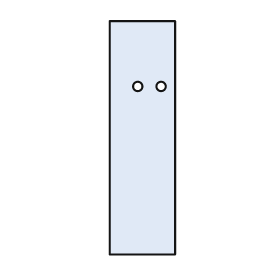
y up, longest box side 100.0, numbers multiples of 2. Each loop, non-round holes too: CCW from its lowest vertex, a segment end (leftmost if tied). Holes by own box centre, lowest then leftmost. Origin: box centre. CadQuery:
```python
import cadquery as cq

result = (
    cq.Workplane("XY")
    .moveTo(-14.0, -50.0)
    .lineTo(14.0, -50.0)
    .lineTo(14.0, 50.0)
    .lineTo(-14.0, 50.0)
    .close()
    .moveTo(-2.0, 22.0)
    .circle(2.0)
    .moveTo(8.0, 22.0)
    .circle(2.0)
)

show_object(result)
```